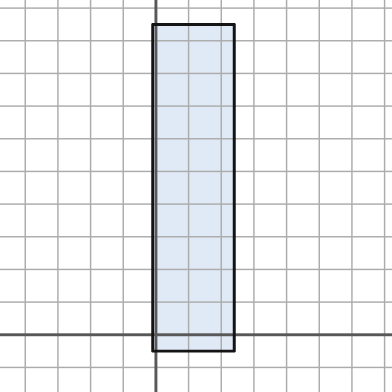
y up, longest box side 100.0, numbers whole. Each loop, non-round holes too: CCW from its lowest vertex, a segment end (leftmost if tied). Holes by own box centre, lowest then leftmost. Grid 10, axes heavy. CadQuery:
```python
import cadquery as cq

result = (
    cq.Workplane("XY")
    .moveTo(-1.0, -5.0)
    .lineTo(24.0, -5.0)
    .lineTo(24.0, 95.0)
    .lineTo(-1.0, 95.0)
    .close()
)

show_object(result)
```